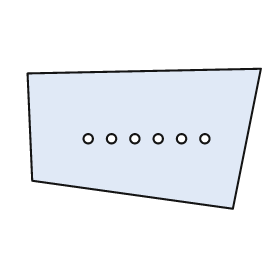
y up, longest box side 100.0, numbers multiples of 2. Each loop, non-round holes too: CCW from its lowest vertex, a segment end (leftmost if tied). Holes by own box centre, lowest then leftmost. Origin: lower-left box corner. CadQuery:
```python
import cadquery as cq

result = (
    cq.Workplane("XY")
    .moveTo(88.0, 0.0)
    .lineTo(100.0, 60.0)
    .lineTo(0.0, 58.0)
    .lineTo(2.0, 12.0)
    .close()
    .moveTo(26.0, 30.0)
    .circle(2.0)
    .moveTo(36.0, 30.0)
    .circle(2.0)
    .moveTo(46.0, 30.0)
    .circle(2.0)
    .moveTo(56.0, 30.0)
    .circle(2.0)
    .moveTo(66.0, 30.0)
    .circle(2.0)
    .moveTo(76.0, 30.0)
    .circle(2.0)
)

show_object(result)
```